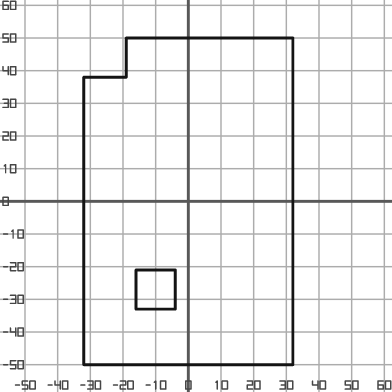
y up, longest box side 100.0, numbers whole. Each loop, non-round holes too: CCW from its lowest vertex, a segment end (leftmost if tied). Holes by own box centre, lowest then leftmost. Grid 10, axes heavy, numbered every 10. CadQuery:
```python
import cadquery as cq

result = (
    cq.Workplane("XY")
    .moveTo(-32.0, -50.0)
    .lineTo(32.0, -50.0)
    .lineTo(32.0, 50.0)
    .lineTo(-19.0, 50.0)
    .lineTo(-19.0, 38.0)
    .lineTo(-32.0, 38.0)
    .close()
    .moveTo(-16.0, -33.0)
    .lineTo(-4.0, -33.0)
    .lineTo(-4.0, -21.0)
    .lineTo(-16.0, -21.0)
    .close()
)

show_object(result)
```